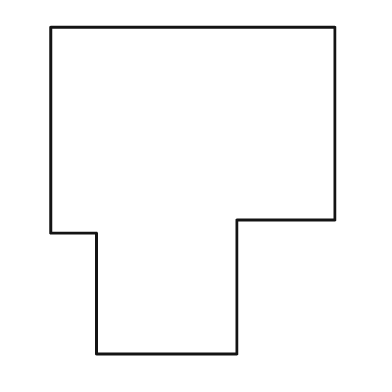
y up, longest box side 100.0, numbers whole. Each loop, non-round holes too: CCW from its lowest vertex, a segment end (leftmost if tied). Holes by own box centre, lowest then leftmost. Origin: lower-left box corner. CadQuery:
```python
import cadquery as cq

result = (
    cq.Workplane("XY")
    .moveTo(14.0, 0.0)
    .lineTo(57.0, 0.0)
    .lineTo(57.0, 41.0)
    .lineTo(87.0, 41.0)
    .lineTo(87.0, 100.0)
    .lineTo(0.0, 100.0)
    .lineTo(0.0, 37.0)
    .lineTo(14.0, 37.0)
    .close()
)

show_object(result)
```